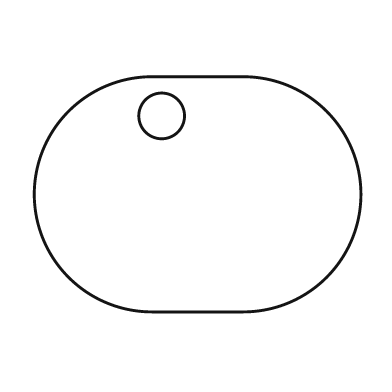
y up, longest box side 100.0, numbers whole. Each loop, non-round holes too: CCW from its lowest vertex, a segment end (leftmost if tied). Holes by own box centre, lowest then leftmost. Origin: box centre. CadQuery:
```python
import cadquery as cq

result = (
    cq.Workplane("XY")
    .moveTo(-14.0, -36.0)
    .lineTo(14.0, -36.0)
    .threePointArc((50.0, 0.0), (14.0, 36.0))
    .lineTo(-14.0, 36.0)
    .threePointArc((-50.0, 0.0), (-14.0, -36.0))
    .close()
    .moveTo(-11.0, 24.0)
    .circle(7.0)
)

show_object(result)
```